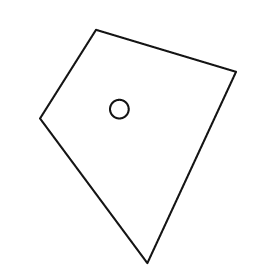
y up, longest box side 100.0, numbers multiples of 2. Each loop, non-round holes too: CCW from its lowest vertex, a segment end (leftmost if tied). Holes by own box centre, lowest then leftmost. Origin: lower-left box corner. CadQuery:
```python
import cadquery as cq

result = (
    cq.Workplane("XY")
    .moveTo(46.0, 0.0)
    .lineTo(84.0, 82.0)
    .lineTo(24.0, 100.0)
    .lineTo(0.0, 62.0)
    .close()
    .moveTo(34.0, 66.0)
    .circle(4.0)
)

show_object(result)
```